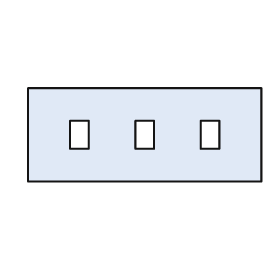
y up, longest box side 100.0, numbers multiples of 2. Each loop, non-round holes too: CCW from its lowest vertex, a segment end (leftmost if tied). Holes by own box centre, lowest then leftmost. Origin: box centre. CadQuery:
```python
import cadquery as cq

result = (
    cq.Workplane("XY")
    .moveTo(-50.0, -20.0)
    .lineTo(50.0, -20.0)
    .lineTo(50.0, 20.0)
    .lineTo(-50.0, 20.0)
    .close()
    .moveTo(-32.0, -6.0)
    .lineTo(-24.0, -6.0)
    .lineTo(-24.0, 6.0)
    .lineTo(-32.0, 6.0)
    .close()
    .moveTo(-4.0, -6.0)
    .lineTo(4.0, -6.0)
    .lineTo(4.0, 6.0)
    .lineTo(-4.0, 6.0)
    .close()
    .moveTo(24.0, -6.0)
    .lineTo(32.0, -6.0)
    .lineTo(32.0, 6.0)
    .lineTo(24.0, 6.0)
    .close()
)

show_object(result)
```